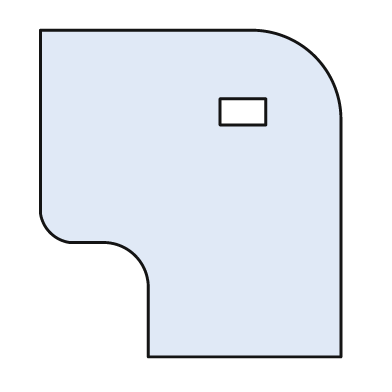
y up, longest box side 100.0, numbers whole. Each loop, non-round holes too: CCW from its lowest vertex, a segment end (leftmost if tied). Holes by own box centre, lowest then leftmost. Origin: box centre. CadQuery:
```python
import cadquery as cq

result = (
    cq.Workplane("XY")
    .moveTo(-13.0, -50.0)
    .lineTo(46.0, -50.0)
    .lineTo(46.0, 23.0)
    .threePointArc((38.0, 42.0), (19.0, 50.0))
    .lineTo(-46.0, 50.0)
    .lineTo(-46.0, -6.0)
    .threePointArc((-43.0, -12.0), (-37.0, -15.0))
    .lineTo(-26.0, -15.0)
    .threePointArc((-17.0, -19.0), (-13.0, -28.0))
    .close()
    .moveTo(9.0, 21.0)
    .lineTo(23.0, 21.0)
    .lineTo(23.0, 29.0)
    .lineTo(9.0, 29.0)
    .close()
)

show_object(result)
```